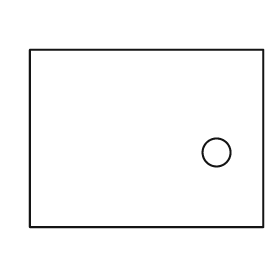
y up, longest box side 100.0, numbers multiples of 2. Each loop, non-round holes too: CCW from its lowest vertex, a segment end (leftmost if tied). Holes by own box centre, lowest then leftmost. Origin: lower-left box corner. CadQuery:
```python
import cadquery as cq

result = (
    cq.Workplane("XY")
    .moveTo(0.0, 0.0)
    .lineTo(100.0, 0.0)
    .lineTo(100.0, 76.0)
    .lineTo(0.0, 76.0)
    .close()
    .moveTo(80.0, 32.0)
    .circle(6.0)
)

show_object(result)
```